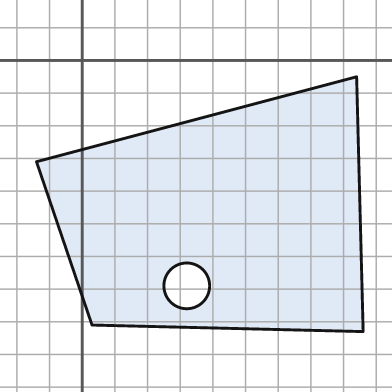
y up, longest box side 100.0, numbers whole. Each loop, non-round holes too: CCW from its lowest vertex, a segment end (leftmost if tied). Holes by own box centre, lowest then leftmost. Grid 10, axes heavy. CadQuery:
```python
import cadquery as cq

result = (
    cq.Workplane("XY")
    .moveTo(86.0, -83.0)
    .lineTo(84.0, -5.0)
    .lineTo(-14.0, -31.0)
    .lineTo(3.0, -81.0)
    .close()
    .moveTo(32.0, -69.0)
    .circle(7.0)
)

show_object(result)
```